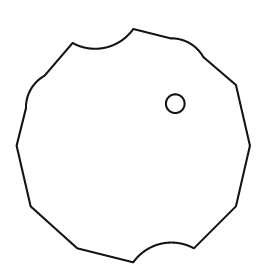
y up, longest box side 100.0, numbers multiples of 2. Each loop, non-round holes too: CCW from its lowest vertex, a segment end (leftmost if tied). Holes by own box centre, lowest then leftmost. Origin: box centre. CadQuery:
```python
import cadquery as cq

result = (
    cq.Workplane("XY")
    .moveTo(0.0, -50.0)
    .threePointArc((12.0, -42.0), (26.0, -44.0))
    .lineTo(44.0, -26.0)
    .lineTo(50.0, 0.0)
    .lineTo(44.0, 26.0)
    .lineTo(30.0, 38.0)
    .threePointArc((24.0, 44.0), (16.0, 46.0))
    .lineTo(0.0, 50.0)
    .threePointArc((-12.0, 42.0), (-26.0, 44.0))
    .lineTo(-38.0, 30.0)
    .threePointArc((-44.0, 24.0), (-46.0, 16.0))
    .lineTo(-50.0, 0.0)
    .lineTo(-44.0, -26.0)
    .lineTo(-24.0, -44.0)
    .close()
    .moveTo(18.0, 18.0)
    .circle(4.0)
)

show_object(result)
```